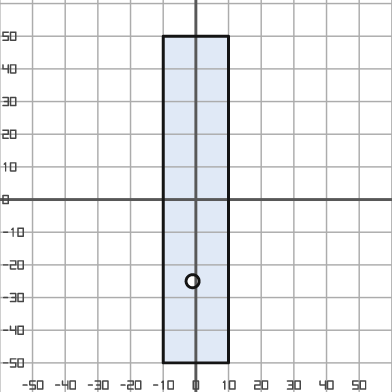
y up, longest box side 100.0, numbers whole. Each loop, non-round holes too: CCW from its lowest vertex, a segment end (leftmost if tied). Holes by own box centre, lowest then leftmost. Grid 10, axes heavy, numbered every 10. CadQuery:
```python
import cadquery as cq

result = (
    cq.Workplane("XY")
    .moveTo(-10.0, -50.0)
    .lineTo(10.0, -50.0)
    .lineTo(10.0, 50.0)
    .lineTo(-10.0, 50.0)
    .close()
    .moveTo(-1.0, -25.0)
    .circle(2.0)
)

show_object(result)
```